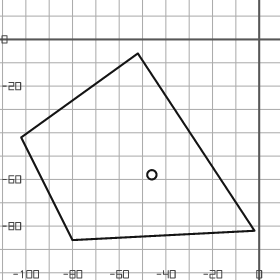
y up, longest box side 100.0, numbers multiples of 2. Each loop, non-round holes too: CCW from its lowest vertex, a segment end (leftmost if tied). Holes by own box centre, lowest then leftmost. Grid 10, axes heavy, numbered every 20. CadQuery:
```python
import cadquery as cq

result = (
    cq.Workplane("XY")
    .moveTo(-80.0, -86.0)
    .lineTo(-2.0, -82.0)
    .lineTo(-52.0, -6.0)
    .lineTo(-102.0, -42.0)
    .close()
    .moveTo(-46.0, -58.0)
    .circle(2.0)
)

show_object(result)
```